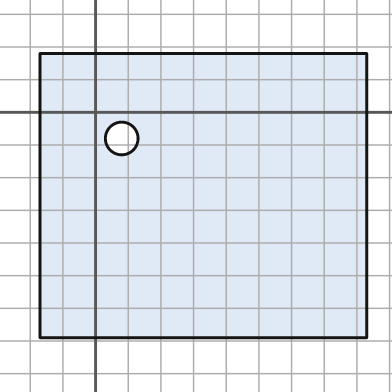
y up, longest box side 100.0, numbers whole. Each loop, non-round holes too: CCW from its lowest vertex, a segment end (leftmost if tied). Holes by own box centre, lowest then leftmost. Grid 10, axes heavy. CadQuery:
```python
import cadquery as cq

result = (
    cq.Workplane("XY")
    .moveTo(-17.0, -69.0)
    .lineTo(83.0, -69.0)
    .lineTo(83.0, 18.0)
    .lineTo(-17.0, 18.0)
    .close()
    .moveTo(8.0, -8.0)
    .circle(5.0)
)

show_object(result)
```